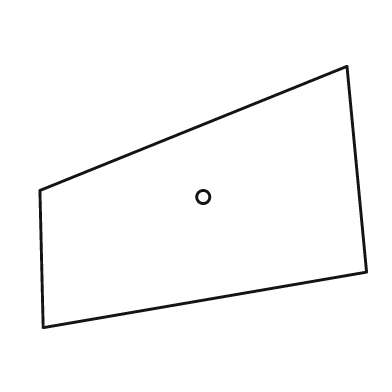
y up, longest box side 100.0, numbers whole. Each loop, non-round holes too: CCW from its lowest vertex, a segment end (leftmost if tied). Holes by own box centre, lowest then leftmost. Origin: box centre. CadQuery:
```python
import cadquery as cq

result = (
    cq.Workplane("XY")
    .moveTo(-49.0, -40.0)
    .lineTo(50.0, -23.0)
    .lineTo(44.0, 40.0)
    .lineTo(-50.0, 2.0)
    .close()
    .moveTo(0.0, 0.0)
    .circle(2.0)
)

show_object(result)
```